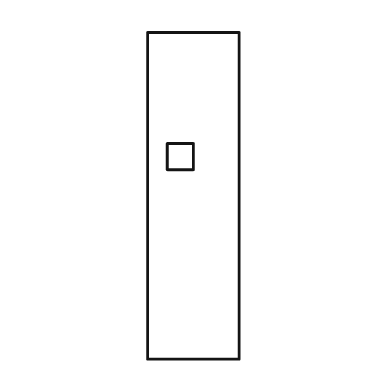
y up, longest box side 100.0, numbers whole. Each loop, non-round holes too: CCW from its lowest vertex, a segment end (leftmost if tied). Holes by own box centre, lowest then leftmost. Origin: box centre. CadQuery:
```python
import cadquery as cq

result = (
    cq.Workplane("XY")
    .moveTo(-14.0, -50.0)
    .lineTo(14.0, -50.0)
    .lineTo(14.0, 50.0)
    .lineTo(-14.0, 50.0)
    .close()
    .moveTo(-8.0, 8.0)
    .lineTo(0.0, 8.0)
    .lineTo(0.0, 16.0)
    .lineTo(-8.0, 16.0)
    .close()
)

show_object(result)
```